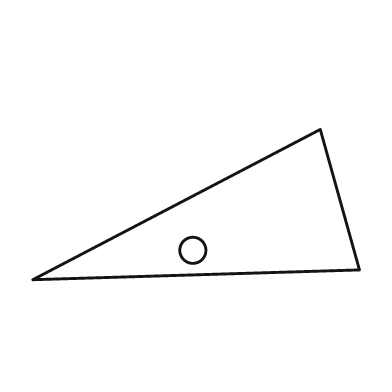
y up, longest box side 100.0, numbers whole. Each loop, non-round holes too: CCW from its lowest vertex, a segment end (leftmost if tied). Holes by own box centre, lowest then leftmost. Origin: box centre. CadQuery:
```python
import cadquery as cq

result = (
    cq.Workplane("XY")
    .moveTo(-50.0, -23.0)
    .lineTo(50.0, -20.0)
    .lineTo(38.0, 23.0)
    .close()
    .moveTo(-1.0, -14.0)
    .circle(4.0)
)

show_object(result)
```